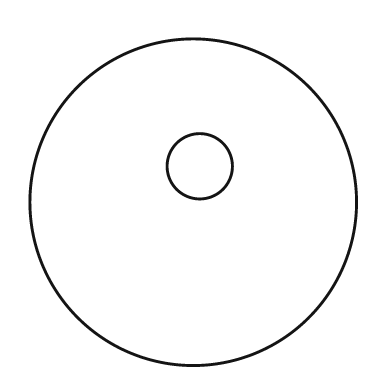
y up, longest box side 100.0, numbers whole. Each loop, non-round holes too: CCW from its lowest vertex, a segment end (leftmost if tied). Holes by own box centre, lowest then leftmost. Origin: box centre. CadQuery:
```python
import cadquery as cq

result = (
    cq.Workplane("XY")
    .moveTo(0.0, 0.0)
    .circle(50.0)
    .moveTo(2.0, 11.0)
    .circle(10.0)
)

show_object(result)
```